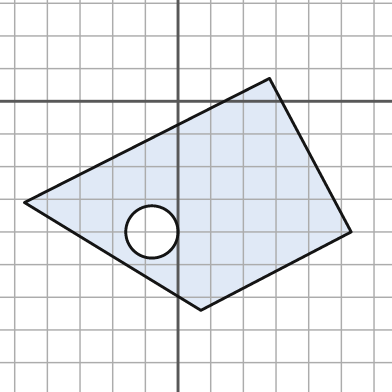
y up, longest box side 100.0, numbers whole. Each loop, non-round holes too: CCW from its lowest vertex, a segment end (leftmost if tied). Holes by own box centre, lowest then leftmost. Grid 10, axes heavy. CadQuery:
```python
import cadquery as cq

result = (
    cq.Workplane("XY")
    .moveTo(7.0, -64.0)
    .lineTo(53.0, -40.0)
    .lineTo(28.0, 7.0)
    .lineTo(-47.0, -31.0)
    .close()
    .moveTo(-8.0, -40.0)
    .circle(8.0)
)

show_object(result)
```